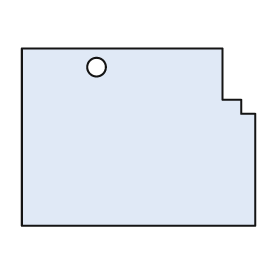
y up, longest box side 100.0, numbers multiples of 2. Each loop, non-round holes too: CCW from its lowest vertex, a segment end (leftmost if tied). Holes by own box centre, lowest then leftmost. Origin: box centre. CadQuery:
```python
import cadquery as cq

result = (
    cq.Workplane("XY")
    .moveTo(-50.0, -38.0)
    .lineTo(50.0, -38.0)
    .lineTo(50.0, 10.0)
    .lineTo(44.0, 10.0)
    .lineTo(44.0, 16.0)
    .lineTo(36.0, 16.0)
    .lineTo(36.0, 38.0)
    .lineTo(-50.0, 38.0)
    .close()
    .moveTo(-18.0, 30.0)
    .circle(4.0)
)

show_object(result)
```